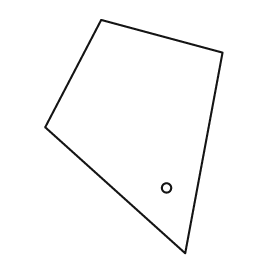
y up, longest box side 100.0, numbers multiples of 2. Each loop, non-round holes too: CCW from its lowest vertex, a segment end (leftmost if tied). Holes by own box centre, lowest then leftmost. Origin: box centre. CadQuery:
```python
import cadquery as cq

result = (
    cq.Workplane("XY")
    .moveTo(22.0, -50.0)
    .lineTo(38.0, 36.0)
    .lineTo(-14.0, 50.0)
    .lineTo(-38.0, 4.0)
    .close()
    .moveTo(14.0, -22.0)
    .circle(2.0)
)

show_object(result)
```